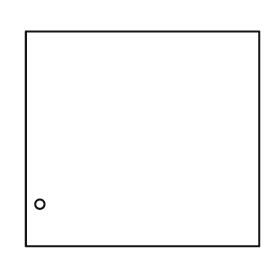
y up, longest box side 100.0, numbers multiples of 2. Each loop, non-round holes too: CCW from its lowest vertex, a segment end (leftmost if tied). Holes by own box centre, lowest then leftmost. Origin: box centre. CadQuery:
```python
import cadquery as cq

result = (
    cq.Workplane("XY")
    .moveTo(-50.0, -46.0)
    .lineTo(50.0, -46.0)
    .lineTo(50.0, 46.0)
    .lineTo(-50.0, 46.0)
    .close()
    .moveTo(-44.0, -28.0)
    .circle(2.0)
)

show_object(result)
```